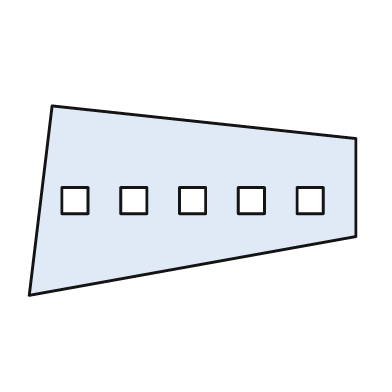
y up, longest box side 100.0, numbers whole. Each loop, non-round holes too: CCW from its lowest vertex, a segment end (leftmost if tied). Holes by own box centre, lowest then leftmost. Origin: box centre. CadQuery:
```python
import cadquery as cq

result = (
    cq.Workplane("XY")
    .moveTo(-50.0, -29.0)
    .lineTo(50.0, -11.0)
    .lineTo(50.0, 19.0)
    .lineTo(-43.0, 29.0)
    .close()
    .moveTo(-40.0, -4.0)
    .lineTo(-32.0, -4.0)
    .lineTo(-32.0, 4.0)
    .lineTo(-40.0, 4.0)
    .close()
    .moveTo(-22.0, -4.0)
    .lineTo(-14.0, -4.0)
    .lineTo(-14.0, 4.0)
    .lineTo(-22.0, 4.0)
    .close()
    .moveTo(-4.0, -4.0)
    .lineTo(4.0, -4.0)
    .lineTo(4.0, 4.0)
    .lineTo(-4.0, 4.0)
    .close()
    .moveTo(14.0, -4.0)
    .lineTo(22.0, -4.0)
    .lineTo(22.0, 4.0)
    .lineTo(14.0, 4.0)
    .close()
    .moveTo(32.0, -4.0)
    .lineTo(40.0, -4.0)
    .lineTo(40.0, 4.0)
    .lineTo(32.0, 4.0)
    .close()
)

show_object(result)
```